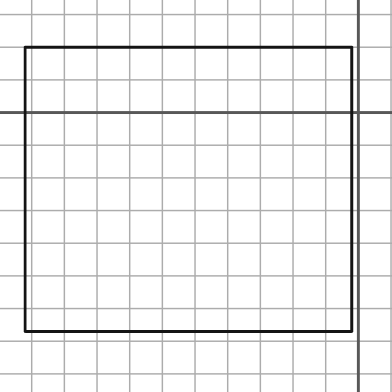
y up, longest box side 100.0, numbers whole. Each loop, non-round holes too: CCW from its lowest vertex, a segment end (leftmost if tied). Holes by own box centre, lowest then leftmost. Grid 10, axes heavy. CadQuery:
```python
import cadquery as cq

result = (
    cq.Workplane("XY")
    .moveTo(-102.0, -67.0)
    .lineTo(-2.0, -67.0)
    .lineTo(-2.0, 20.0)
    .lineTo(-102.0, 20.0)
    .close()
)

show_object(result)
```